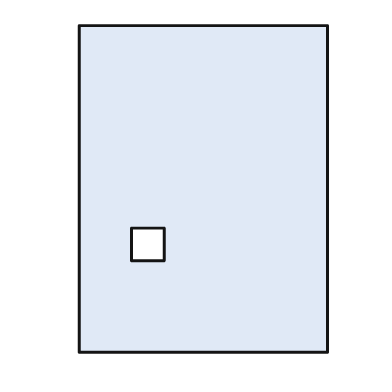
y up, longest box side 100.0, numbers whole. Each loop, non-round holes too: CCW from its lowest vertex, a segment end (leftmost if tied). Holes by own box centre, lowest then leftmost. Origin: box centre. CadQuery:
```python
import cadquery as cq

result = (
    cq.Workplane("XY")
    .moveTo(-38.0, -50.0)
    .lineTo(38.0, -50.0)
    .lineTo(38.0, 50.0)
    .lineTo(-38.0, 50.0)
    .close()
    .moveTo(-22.0, -22.0)
    .lineTo(-12.0, -22.0)
    .lineTo(-12.0, -12.0)
    .lineTo(-22.0, -12.0)
    .close()
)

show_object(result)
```